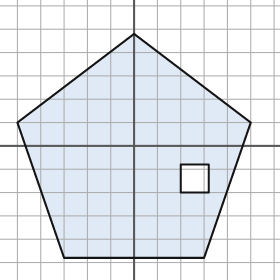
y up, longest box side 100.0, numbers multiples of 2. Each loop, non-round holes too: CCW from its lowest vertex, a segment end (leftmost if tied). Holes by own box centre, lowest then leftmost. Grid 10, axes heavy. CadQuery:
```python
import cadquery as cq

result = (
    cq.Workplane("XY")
    .moveTo(-30.0, -48.0)
    .lineTo(30.0, -48.0)
    .lineTo(50.0, 10.0)
    .lineTo(0.0, 48.0)
    .lineTo(-50.0, 10.0)
    .close()
    .moveTo(20.0, -20.0)
    .lineTo(32.0, -20.0)
    .lineTo(32.0, -8.0)
    .lineTo(20.0, -8.0)
    .close()
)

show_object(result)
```